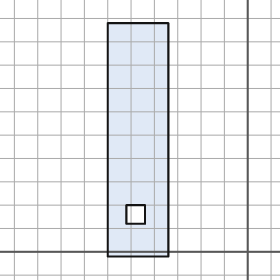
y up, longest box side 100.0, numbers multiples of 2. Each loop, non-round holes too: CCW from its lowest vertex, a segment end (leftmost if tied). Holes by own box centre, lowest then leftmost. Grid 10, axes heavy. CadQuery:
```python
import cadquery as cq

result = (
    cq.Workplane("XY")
    .moveTo(-60.0, -2.0)
    .lineTo(-34.0, -2.0)
    .lineTo(-34.0, 98.0)
    .lineTo(-60.0, 98.0)
    .close()
    .moveTo(-52.0, 12.0)
    .lineTo(-44.0, 12.0)
    .lineTo(-44.0, 20.0)
    .lineTo(-52.0, 20.0)
    .close()
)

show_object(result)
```